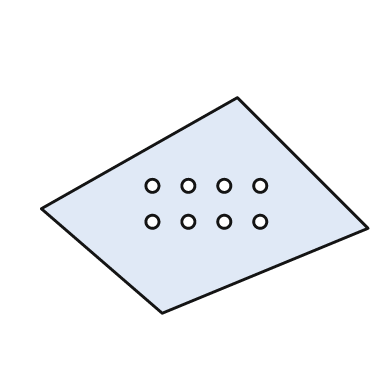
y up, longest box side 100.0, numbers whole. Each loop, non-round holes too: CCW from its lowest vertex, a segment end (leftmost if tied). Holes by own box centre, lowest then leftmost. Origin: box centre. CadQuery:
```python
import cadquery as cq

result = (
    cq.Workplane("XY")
    .moveTo(-13.0, -33.0)
    .lineTo(50.0, -7.0)
    .lineTo(10.0, 33.0)
    .lineTo(-50.0, -1.0)
    .close()
    .moveTo(-16.0, -5.0)
    .circle(2.0)
    .moveTo(-5.0, -5.0)
    .circle(2.0)
    .moveTo(6.0, -5.0)
    .circle(2.0)
    .moveTo(17.0, -5.0)
    .circle(2.0)
    .moveTo(-16.0, 6.0)
    .circle(2.0)
    .moveTo(-5.0, 6.0)
    .circle(2.0)
    .moveTo(6.0, 6.0)
    .circle(2.0)
    .moveTo(17.0, 6.0)
    .circle(2.0)
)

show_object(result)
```